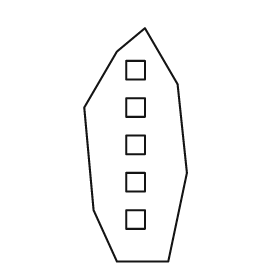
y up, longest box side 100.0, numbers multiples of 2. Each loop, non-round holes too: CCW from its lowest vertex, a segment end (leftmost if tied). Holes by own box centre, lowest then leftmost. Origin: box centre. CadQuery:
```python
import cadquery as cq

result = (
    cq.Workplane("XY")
    .moveTo(-8.0, -50.0)
    .lineTo(14.0, -50.0)
    .lineTo(22.0, -12.0)
    .lineTo(18.0, 26.0)
    .lineTo(4.0, 50.0)
    .lineTo(-8.0, 40.0)
    .lineTo(-22.0, 16.0)
    .lineTo(-18.0, -28.0)
    .close()
    .moveTo(-4.0, -36.0)
    .lineTo(4.0, -36.0)
    .lineTo(4.0, -28.0)
    .lineTo(-4.0, -28.0)
    .close()
    .moveTo(-4.0, -20.0)
    .lineTo(4.0, -20.0)
    .lineTo(4.0, -12.0)
    .lineTo(-4.0, -12.0)
    .close()
    .moveTo(-4.0, -4.0)
    .lineTo(4.0, -4.0)
    .lineTo(4.0, 4.0)
    .lineTo(-4.0, 4.0)
    .close()
    .moveTo(-4.0, 12.0)
    .lineTo(4.0, 12.0)
    .lineTo(4.0, 20.0)
    .lineTo(-4.0, 20.0)
    .close()
    .moveTo(-4.0, 28.0)
    .lineTo(4.0, 28.0)
    .lineTo(4.0, 36.0)
    .lineTo(-4.0, 36.0)
    .close()
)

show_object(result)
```